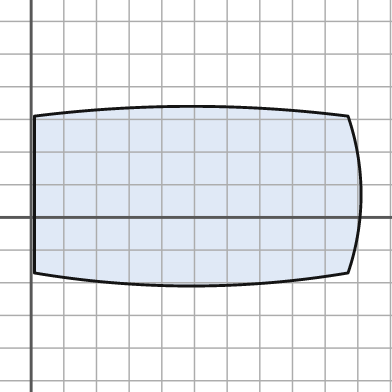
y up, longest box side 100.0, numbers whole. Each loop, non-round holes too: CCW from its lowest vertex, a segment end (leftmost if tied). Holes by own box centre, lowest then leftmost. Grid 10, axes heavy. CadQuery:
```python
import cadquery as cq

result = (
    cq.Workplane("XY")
    .moveTo(1.0, -17.0)
    .threePointArc((49.0, -21.0), (97.0, -17.0))
    .threePointArc((101.0, 7.0), (97.0, 31.0))
    .threePointArc((49.0, 34.0), (1.0, 31.0))
    .close()
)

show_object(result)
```